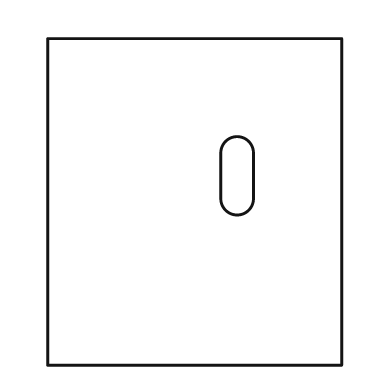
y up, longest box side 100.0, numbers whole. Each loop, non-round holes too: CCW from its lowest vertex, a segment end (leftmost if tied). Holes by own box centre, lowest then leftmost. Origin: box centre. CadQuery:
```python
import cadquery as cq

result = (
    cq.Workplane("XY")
    .moveTo(-45.0, -50.0)
    .lineTo(45.0, -50.0)
    .lineTo(45.0, 50.0)
    .lineTo(-45.0, 50.0)
    .close()
    .moveTo(8.0, 1.0)
    .threePointArc((13.0, -4.0), (18.0, 1.0))
    .lineTo(18.0, 15.0)
    .threePointArc((13.0, 20.0), (8.0, 15.0))
    .close()
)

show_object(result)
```